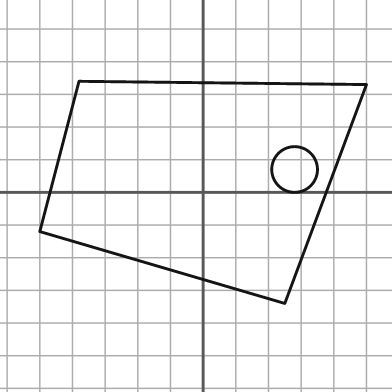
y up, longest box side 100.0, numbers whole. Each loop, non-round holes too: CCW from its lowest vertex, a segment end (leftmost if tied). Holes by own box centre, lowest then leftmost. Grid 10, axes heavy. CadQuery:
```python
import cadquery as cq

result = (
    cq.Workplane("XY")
    .moveTo(25.0, -34.0)
    .lineTo(50.0, 33.0)
    .lineTo(-38.0, 34.0)
    .lineTo(-50.0, -12.0)
    .close()
    .moveTo(28.0, 7.0)
    .circle(7.0)
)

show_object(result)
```